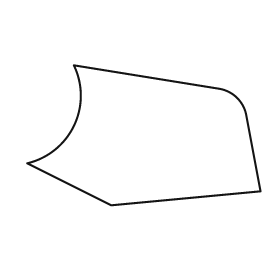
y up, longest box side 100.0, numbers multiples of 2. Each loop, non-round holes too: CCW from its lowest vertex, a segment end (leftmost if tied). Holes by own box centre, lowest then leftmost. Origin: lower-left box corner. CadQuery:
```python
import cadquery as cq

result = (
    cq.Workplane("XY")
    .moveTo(36.0, 0.0)
    .lineTo(100.0, 6.0)
    .lineTo(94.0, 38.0)
    .threePointArc((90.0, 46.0), (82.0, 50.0))
    .lineTo(20.0, 60.0)
    .threePointArc((20.0, 34.0), (0.0, 18.0))
    .close()
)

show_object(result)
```